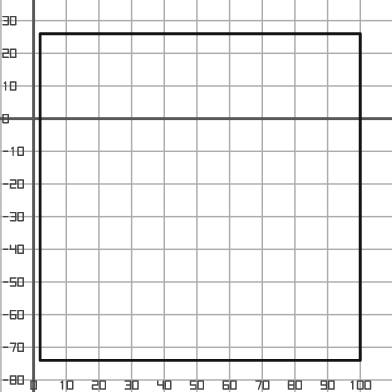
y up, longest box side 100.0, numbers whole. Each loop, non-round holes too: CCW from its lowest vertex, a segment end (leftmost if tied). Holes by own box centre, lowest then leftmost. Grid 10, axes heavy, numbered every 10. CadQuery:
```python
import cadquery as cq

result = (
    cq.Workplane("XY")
    .moveTo(2.0, -74.0)
    .lineTo(100.0, -74.0)
    .lineTo(100.0, 26.0)
    .lineTo(2.0, 26.0)
    .close()
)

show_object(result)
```